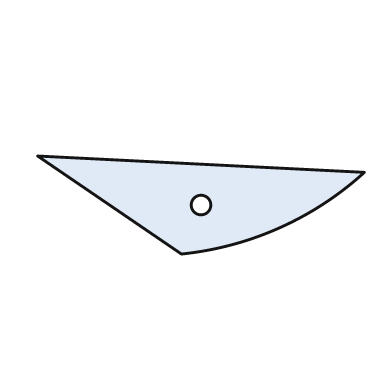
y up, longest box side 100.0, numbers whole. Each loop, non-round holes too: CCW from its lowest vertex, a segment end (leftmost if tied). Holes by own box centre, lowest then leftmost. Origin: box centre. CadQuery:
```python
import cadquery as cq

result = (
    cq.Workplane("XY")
    .moveTo(-6.0, -15.0)
    .threePointArc((24.0, -7.0), (50.0, 10.0))
    .lineTo(-50.0, 15.0)
    .close()
    .moveTo(0.0, 0.0)
    .circle(3.0)
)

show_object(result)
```